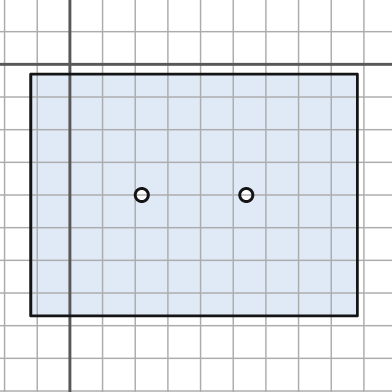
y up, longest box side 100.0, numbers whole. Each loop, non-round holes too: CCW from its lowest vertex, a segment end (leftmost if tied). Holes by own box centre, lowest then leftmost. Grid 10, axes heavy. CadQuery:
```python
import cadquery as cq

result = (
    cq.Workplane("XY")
    .moveTo(-12.0, -77.0)
    .lineTo(88.0, -77.0)
    .lineTo(88.0, -3.0)
    .lineTo(-12.0, -3.0)
    .close()
    .moveTo(22.0, -40.0)
    .circle(2.0)
    .moveTo(54.0, -40.0)
    .circle(2.0)
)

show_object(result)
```